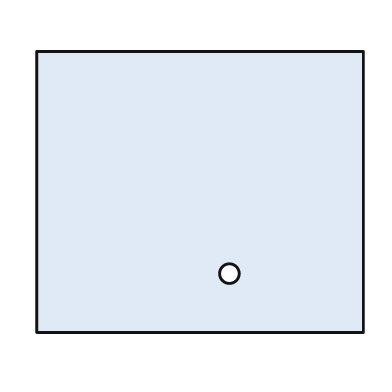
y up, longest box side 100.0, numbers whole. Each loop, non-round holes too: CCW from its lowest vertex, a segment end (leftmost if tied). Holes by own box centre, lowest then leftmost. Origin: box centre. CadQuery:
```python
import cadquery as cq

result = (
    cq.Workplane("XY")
    .moveTo(-50.0, -43.0)
    .lineTo(50.0, -43.0)
    .lineTo(50.0, 43.0)
    .lineTo(-50.0, 43.0)
    .close()
    .moveTo(9.0, -25.0)
    .circle(3.0)
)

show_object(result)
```